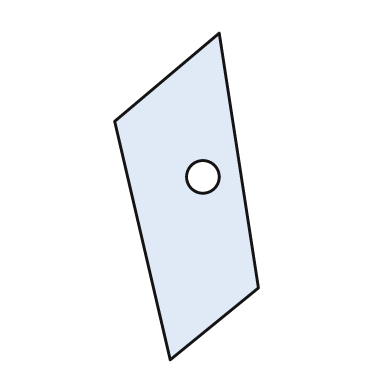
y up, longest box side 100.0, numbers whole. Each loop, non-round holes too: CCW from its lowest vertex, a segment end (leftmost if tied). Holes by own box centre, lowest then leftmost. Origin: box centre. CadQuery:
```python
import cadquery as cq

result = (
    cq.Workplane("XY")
    .moveTo(-5.0, -50.0)
    .lineTo(22.0, -28.0)
    .lineTo(10.0, 50.0)
    .lineTo(-22.0, 23.0)
    .close()
    .moveTo(5.0, 6.0)
    .circle(5.0)
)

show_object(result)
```